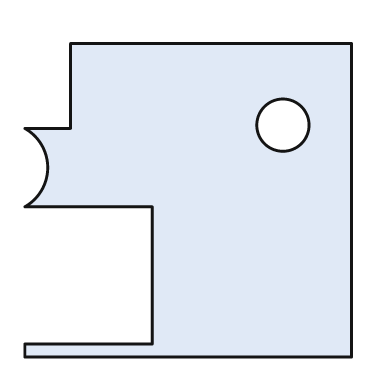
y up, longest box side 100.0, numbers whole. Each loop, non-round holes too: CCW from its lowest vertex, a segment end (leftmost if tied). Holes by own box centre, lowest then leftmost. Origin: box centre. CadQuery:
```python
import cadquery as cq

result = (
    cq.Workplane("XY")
    .moveTo(-50.0, -48.0)
    .lineTo(50.0, -48.0)
    .lineTo(50.0, 48.0)
    .lineTo(-36.0, 48.0)
    .lineTo(-36.0, 22.0)
    .lineTo(-50.0, 22.0)
    .threePointArc((-43.0, 10.0), (-50.0, -2.0))
    .lineTo(-11.0, -2.0)
    .lineTo(-11.0, -44.0)
    .lineTo(-50.0, -44.0)
    .close()
    .moveTo(29.0, 23.0)
    .circle(8.0)
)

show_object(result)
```